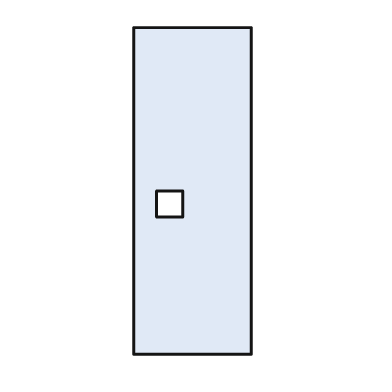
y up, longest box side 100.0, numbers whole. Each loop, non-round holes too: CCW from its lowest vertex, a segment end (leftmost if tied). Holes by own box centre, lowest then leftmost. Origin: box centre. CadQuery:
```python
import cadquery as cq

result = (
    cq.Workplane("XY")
    .moveTo(-18.0, -50.0)
    .lineTo(18.0, -50.0)
    .lineTo(18.0, 50.0)
    .lineTo(-18.0, 50.0)
    .close()
    .moveTo(-11.0, -8.0)
    .lineTo(-3.0, -8.0)
    .lineTo(-3.0, 0.0)
    .lineTo(-11.0, 0.0)
    .close()
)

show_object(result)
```